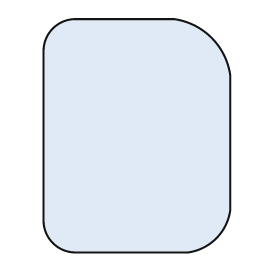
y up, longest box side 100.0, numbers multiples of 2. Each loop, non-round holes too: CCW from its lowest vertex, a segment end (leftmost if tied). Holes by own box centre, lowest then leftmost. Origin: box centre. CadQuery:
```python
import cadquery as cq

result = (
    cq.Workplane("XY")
    .moveTo(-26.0, -50.0)
    .lineTo(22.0, -50.0)
    .threePointArc((34.0, -44.0), (40.0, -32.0))
    .lineTo(40.0, 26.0)
    .threePointArc((32.0, 42.0), (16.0, 50.0))
    .lineTo(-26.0, 50.0)
    .threePointArc((-36.0, 46.0), (-40.0, 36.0))
    .lineTo(-40.0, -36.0)
    .threePointArc((-36.0, -46.0), (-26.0, -50.0))
    .close()
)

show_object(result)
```